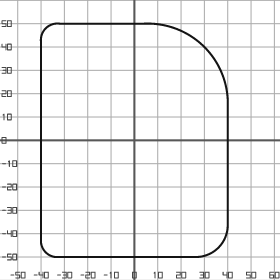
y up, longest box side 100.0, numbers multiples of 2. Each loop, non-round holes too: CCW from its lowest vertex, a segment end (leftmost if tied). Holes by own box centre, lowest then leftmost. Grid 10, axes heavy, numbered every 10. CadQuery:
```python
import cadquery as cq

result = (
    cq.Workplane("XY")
    .moveTo(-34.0, -50.0)
    .lineTo(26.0, -50.0)
    .threePointArc((36.0, -46.0), (40.0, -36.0))
    .lineTo(40.0, 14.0)
    .threePointArc((30.0, 40.0), (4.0, 50.0))
    .lineTo(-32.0, 50.0)
    .threePointArc((-38.0, 48.0), (-40.0, 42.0))
    .lineTo(-40.0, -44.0)
    .threePointArc((-38.0, -48.0), (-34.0, -50.0))
    .close()
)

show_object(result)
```